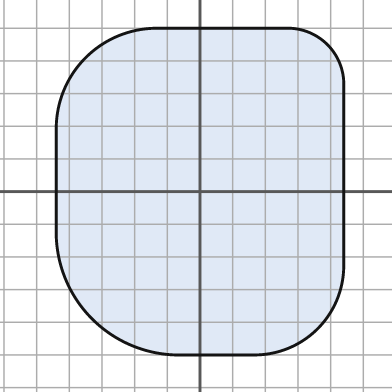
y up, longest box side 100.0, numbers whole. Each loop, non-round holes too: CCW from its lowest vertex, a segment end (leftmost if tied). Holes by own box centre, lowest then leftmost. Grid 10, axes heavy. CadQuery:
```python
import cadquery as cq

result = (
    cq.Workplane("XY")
    .moveTo(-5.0, -50.0)
    .lineTo(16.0, -50.0)
    .threePointArc((36.0, -42.0), (44.0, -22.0))
    .lineTo(44.0, 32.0)
    .threePointArc((39.0, 45.0), (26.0, 50.0))
    .lineTo(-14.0, 50.0)
    .threePointArc((-35.0, 41.0), (-44.0, 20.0))
    .lineTo(-44.0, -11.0)
    .threePointArc((-33.0, -39.0), (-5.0, -50.0))
    .close()
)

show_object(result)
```